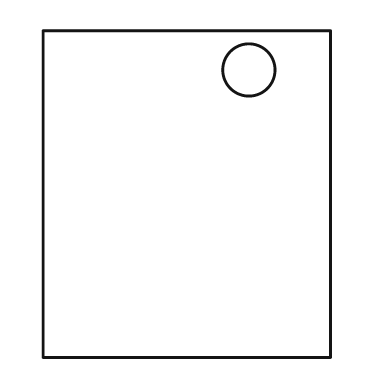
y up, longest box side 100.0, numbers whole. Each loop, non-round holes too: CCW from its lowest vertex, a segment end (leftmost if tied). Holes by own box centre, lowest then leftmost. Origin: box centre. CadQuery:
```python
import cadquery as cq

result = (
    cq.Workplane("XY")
    .moveTo(-44.0, -50.0)
    .lineTo(44.0, -50.0)
    .lineTo(44.0, 50.0)
    .lineTo(-44.0, 50.0)
    .close()
    .moveTo(19.0, 38.0)
    .circle(8.0)
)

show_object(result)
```